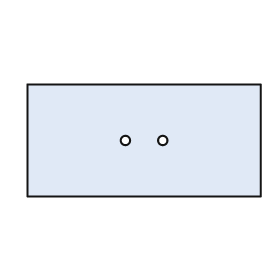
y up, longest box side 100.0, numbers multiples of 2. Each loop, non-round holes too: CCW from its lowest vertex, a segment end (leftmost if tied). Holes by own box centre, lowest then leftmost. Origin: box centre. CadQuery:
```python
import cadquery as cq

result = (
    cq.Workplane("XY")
    .moveTo(-50.0, -24.0)
    .lineTo(50.0, -24.0)
    .lineTo(50.0, 24.0)
    .lineTo(-50.0, 24.0)
    .close()
    .moveTo(-8.0, 0.0)
    .circle(2.0)
    .moveTo(8.0, 0.0)
    .circle(2.0)
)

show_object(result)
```